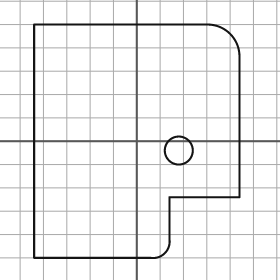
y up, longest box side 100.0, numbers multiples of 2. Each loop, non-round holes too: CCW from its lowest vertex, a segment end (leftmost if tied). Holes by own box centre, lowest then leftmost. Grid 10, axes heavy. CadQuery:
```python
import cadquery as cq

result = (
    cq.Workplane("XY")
    .moveTo(-44.0, -50.0)
    .lineTo(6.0, -50.0)
    .threePointArc((12.0, -48.0), (14.0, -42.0))
    .lineTo(14.0, -24.0)
    .lineTo(44.0, -24.0)
    .lineTo(44.0, 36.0)
    .threePointArc((40.0, 46.0), (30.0, 50.0))
    .lineTo(-44.0, 50.0)
    .close()
    .moveTo(18.0, -4.0)
    .circle(6.0)
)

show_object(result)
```